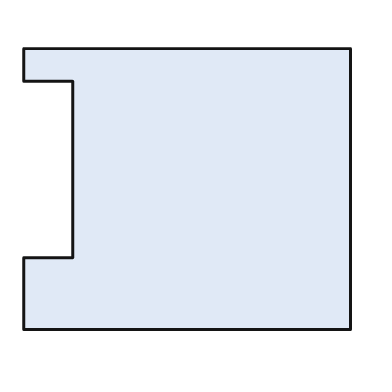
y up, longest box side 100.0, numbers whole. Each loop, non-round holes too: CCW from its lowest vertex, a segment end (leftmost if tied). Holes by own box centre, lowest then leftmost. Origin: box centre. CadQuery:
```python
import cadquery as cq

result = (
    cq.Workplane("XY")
    .moveTo(-50.0, -43.0)
    .lineTo(50.0, -43.0)
    .lineTo(50.0, 43.0)
    .lineTo(-50.0, 43.0)
    .lineTo(-50.0, 33.0)
    .lineTo(-35.0, 33.0)
    .lineTo(-35.0, -21.0)
    .lineTo(-50.0, -21.0)
    .close()
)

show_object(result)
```